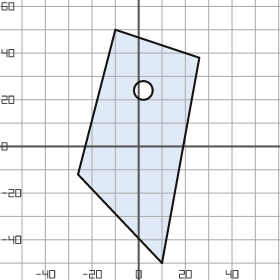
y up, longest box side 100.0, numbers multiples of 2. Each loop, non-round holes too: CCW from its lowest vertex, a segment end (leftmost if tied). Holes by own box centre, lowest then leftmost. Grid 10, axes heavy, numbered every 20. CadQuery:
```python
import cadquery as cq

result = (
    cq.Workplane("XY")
    .moveTo(10.0, -50.0)
    .lineTo(26.0, 38.0)
    .lineTo(-10.0, 50.0)
    .lineTo(-26.0, -12.0)
    .close()
    .moveTo(2.0, 24.0)
    .circle(4.0)
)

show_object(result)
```